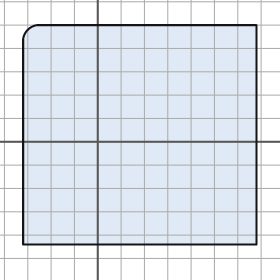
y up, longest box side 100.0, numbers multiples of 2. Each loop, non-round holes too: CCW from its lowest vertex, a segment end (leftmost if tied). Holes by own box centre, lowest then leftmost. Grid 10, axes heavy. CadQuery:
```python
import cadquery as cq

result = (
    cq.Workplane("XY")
    .moveTo(-32.0, -44.0)
    .lineTo(68.0, -44.0)
    .lineTo(68.0, 50.0)
    .lineTo(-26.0, 50.0)
    .threePointArc((-30.0, 48.0), (-32.0, 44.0))
    .close()
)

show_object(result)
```